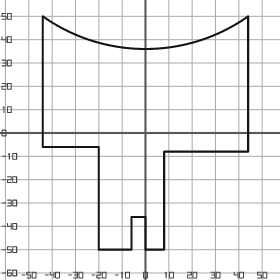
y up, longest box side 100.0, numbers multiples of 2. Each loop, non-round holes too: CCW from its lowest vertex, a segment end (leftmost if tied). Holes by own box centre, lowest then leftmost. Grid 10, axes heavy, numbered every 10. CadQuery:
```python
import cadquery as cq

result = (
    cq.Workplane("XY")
    .moveTo(-20.0, -50.0)
    .lineTo(-6.0, -50.0)
    .lineTo(-6.0, -36.0)
    .lineTo(0.0, -36.0)
    .lineTo(0.0, -50.0)
    .lineTo(8.0, -50.0)
    .lineTo(8.0, -8.0)
    .lineTo(44.0, -8.0)
    .lineTo(44.0, 50.0)
    .threePointArc((0.0, 36.0), (-44.0, 50.0))
    .lineTo(-44.0, -6.0)
    .lineTo(-20.0, -6.0)
    .close()
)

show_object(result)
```